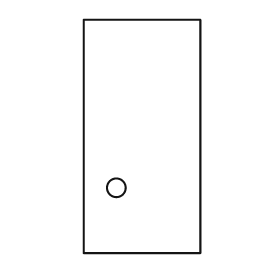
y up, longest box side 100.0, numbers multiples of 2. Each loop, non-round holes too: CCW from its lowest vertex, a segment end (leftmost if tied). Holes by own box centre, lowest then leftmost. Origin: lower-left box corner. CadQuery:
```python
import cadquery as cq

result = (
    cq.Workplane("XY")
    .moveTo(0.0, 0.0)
    .lineTo(50.0, 0.0)
    .lineTo(50.0, 100.0)
    .lineTo(0.0, 100.0)
    .close()
    .moveTo(14.0, 28.0)
    .circle(4.0)
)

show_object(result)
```